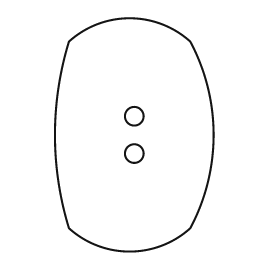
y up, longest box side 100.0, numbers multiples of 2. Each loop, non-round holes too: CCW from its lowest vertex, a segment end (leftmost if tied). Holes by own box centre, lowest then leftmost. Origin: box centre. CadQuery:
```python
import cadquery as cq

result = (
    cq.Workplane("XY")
    .moveTo(-28.0, -40.0)
    .threePointArc((-2.0, -50.0), (24.0, -40.0))
    .threePointArc((34.0, 0.0), (24.0, 40.0))
    .threePointArc((-2.0, 50.0), (-28.0, 40.0))
    .threePointArc((-34.0, 0.0), (-28.0, -40.0))
    .close()
    .moveTo(0.0, -8.0)
    .circle(4.0)
    .moveTo(0.0, 8.0)
    .circle(4.0)
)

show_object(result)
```